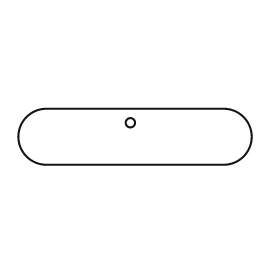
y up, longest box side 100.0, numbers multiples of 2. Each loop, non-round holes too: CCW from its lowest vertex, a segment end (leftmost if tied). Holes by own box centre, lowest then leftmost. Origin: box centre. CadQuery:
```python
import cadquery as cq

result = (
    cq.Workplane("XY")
    .moveTo(-38.0, -12.0)
    .lineTo(38.0, -12.0)
    .threePointArc((50.0, 0.0), (38.0, 12.0))
    .lineTo(-38.0, 12.0)
    .threePointArc((-50.0, 0.0), (-38.0, -12.0))
    .close()
    .moveTo(-2.0, 6.0)
    .circle(2.0)
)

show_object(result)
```